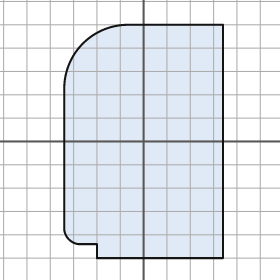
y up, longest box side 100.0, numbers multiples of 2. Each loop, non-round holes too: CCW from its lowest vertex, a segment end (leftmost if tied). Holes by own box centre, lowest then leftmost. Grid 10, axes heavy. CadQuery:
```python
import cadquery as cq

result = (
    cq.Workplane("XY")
    .moveTo(-20.0, -50.0)
    .lineTo(34.0, -50.0)
    .lineTo(34.0, 50.0)
    .lineTo(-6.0, 50.0)
    .threePointArc((-26.0, 42.0), (-34.0, 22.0))
    .lineTo(-34.0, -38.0)
    .threePointArc((-32.0, -42.0), (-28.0, -44.0))
    .lineTo(-20.0, -44.0)
    .close()
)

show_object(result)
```